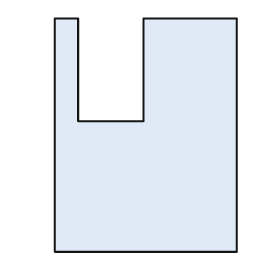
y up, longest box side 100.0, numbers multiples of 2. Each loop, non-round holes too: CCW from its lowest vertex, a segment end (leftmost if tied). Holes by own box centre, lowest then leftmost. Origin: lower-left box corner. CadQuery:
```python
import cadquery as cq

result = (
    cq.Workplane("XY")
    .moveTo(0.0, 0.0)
    .lineTo(78.0, 0.0)
    .lineTo(78.0, 100.0)
    .lineTo(38.0, 100.0)
    .lineTo(38.0, 56.0)
    .lineTo(10.0, 56.0)
    .lineTo(10.0, 100.0)
    .lineTo(0.0, 100.0)
    .close()
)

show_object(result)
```